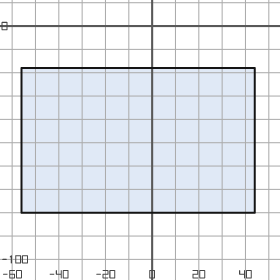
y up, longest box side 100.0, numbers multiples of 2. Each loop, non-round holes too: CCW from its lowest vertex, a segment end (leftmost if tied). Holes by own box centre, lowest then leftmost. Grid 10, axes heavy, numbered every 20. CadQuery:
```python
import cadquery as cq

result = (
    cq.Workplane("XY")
    .moveTo(-56.0, -80.0)
    .lineTo(44.0, -80.0)
    .lineTo(44.0, -18.0)
    .lineTo(-56.0, -18.0)
    .close()
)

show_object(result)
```